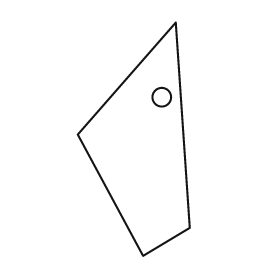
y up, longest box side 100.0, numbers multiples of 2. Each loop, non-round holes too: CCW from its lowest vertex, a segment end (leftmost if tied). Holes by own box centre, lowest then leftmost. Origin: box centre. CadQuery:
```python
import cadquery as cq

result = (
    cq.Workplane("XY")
    .moveTo(4.0, -50.0)
    .lineTo(24.0, -38.0)
    .lineTo(18.0, 50.0)
    .lineTo(-24.0, 2.0)
    .close()
    .moveTo(12.0, 18.0)
    .circle(4.0)
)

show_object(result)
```